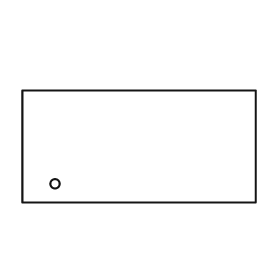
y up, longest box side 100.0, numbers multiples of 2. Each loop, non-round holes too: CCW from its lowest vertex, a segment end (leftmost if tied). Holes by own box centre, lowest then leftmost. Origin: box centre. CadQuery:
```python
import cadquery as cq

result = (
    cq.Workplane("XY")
    .moveTo(-50.0, -24.0)
    .lineTo(50.0, -24.0)
    .lineTo(50.0, 24.0)
    .lineTo(-50.0, 24.0)
    .close()
    .moveTo(-36.0, -16.0)
    .circle(2.0)
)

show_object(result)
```